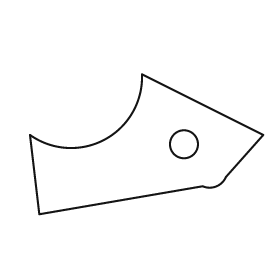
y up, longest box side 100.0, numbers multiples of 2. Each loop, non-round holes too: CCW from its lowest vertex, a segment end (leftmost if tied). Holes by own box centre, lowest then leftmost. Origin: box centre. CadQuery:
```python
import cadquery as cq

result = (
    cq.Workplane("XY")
    .moveTo(-46.0, -30.0)
    .lineTo(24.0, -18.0)
    .threePointArc((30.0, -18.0), (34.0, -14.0))
    .lineTo(50.0, 4.0)
    .lineTo(-2.0, 30.0)
    .threePointArc((-18.0, 2.0), (-50.0, 4.0))
    .close()
    .moveTo(16.0, 0.0)
    .circle(6.0)
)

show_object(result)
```